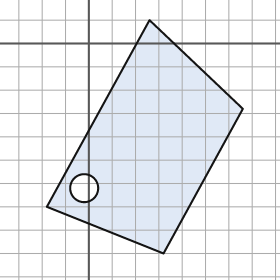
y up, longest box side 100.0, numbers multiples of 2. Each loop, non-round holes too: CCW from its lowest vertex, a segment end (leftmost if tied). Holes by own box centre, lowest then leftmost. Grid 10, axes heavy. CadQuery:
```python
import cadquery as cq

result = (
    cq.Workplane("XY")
    .moveTo(32.0, -90.0)
    .lineTo(66.0, -28.0)
    .lineTo(26.0, 10.0)
    .lineTo(-18.0, -70.0)
    .close()
    .moveTo(-2.0, -62.0)
    .circle(6.0)
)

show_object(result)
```